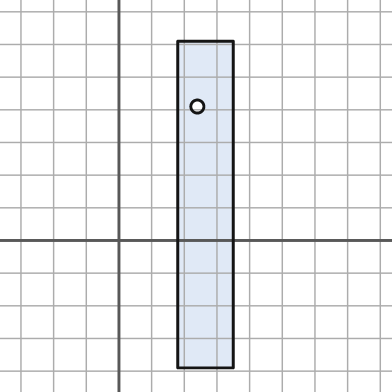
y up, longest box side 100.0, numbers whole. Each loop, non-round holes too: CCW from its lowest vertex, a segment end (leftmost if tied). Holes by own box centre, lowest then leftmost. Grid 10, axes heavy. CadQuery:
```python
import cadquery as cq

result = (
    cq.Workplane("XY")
    .moveTo(18.0, -39.0)
    .lineTo(35.0, -39.0)
    .lineTo(35.0, 61.0)
    .lineTo(18.0, 61.0)
    .close()
    .moveTo(24.0, 41.0)
    .circle(2.0)
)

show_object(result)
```